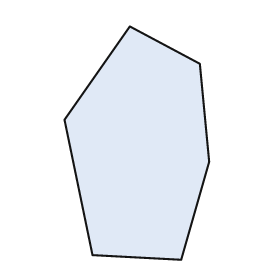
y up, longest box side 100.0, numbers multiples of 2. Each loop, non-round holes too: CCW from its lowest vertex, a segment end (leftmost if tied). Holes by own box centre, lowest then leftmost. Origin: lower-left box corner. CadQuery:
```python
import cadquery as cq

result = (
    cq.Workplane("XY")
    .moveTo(50.0, 0.0)
    .lineTo(62.0, 42.0)
    .lineTo(58.0, 84.0)
    .lineTo(28.0, 100.0)
    .lineTo(0.0, 60.0)
    .lineTo(12.0, 2.0)
    .close()
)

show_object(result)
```